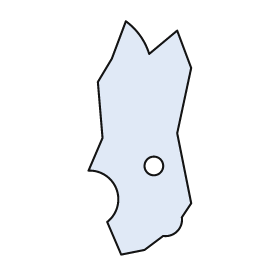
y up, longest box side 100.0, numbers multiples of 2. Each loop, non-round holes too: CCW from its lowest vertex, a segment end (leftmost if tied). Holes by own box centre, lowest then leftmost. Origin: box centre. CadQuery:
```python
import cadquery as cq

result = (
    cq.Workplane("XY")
    .moveTo(-8.0, -50.0)
    .lineTo(2.0, -48.0)
    .lineTo(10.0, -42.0)
    .threePointArc((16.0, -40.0), (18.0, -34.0))
    .lineTo(22.0, -28.0)
    .lineTo(16.0, 2.0)
    .lineTo(22.0, 30.0)
    .lineTo(16.0, 46.0)
    .lineTo(4.0, 36.0)
    .threePointArc((0.0, 44.0), (-6.0, 50.0))
    .lineTo(-12.0, 34.0)
    .lineTo(-18.0, 24.0)
    .lineTo(-16.0, 0.0)
    .lineTo(-22.0, -14.0)
    .threePointArc((-10.0, -22.0), (-14.0, -36.0))
    .close()
    .moveTo(6.0, -12.0)
    .circle(4.0)
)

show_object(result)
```